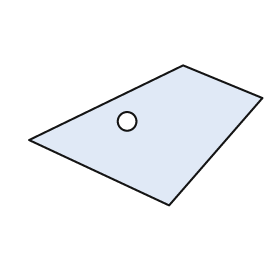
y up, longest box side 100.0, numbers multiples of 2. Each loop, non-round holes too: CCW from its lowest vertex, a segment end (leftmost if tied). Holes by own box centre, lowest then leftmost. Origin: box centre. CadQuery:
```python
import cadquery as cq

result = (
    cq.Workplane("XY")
    .moveTo(10.0, -30.0)
    .lineTo(50.0, 16.0)
    .lineTo(16.0, 30.0)
    .lineTo(-50.0, -2.0)
    .close()
    .moveTo(-8.0, 6.0)
    .circle(4.0)
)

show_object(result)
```